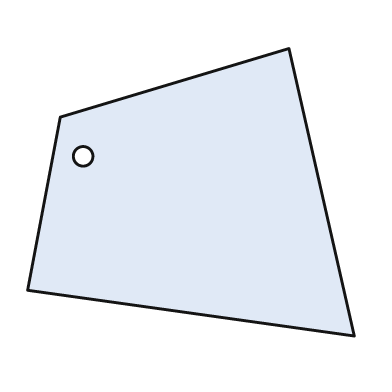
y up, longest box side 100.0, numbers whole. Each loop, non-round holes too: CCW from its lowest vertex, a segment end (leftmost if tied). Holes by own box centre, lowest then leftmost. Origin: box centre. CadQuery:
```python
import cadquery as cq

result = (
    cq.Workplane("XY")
    .moveTo(50.0, -44.0)
    .lineTo(30.0, 44.0)
    .lineTo(-40.0, 23.0)
    .lineTo(-50.0, -30.0)
    .close()
    .moveTo(-33.0, 11.0)
    .circle(3.0)
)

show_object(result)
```